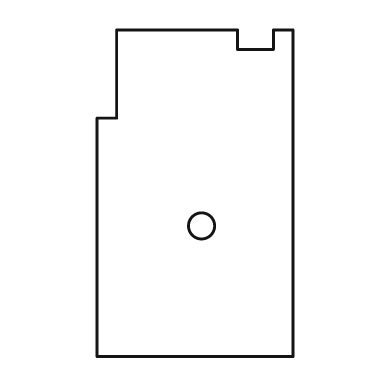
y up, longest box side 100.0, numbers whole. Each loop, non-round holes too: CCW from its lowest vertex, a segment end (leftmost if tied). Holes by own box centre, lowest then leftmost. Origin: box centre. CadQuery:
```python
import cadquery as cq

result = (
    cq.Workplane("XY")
    .moveTo(-30.0, -50.0)
    .lineTo(30.0, -50.0)
    .lineTo(30.0, 50.0)
    .lineTo(24.0, 50.0)
    .lineTo(24.0, 44.0)
    .lineTo(13.0, 44.0)
    .lineTo(13.0, 50.0)
    .lineTo(-24.0, 50.0)
    .lineTo(-24.0, 23.0)
    .lineTo(-30.0, 23.0)
    .close()
    .moveTo(2.0, -10.0)
    .circle(4.0)
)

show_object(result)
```